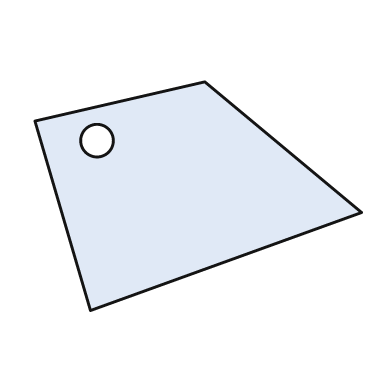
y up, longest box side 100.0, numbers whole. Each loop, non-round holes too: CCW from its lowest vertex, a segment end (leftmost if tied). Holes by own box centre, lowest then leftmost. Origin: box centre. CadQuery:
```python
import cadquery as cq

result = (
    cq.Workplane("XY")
    .moveTo(-33.0, -35.0)
    .lineTo(50.0, -5.0)
    .lineTo(2.0, 35.0)
    .lineTo(-50.0, 23.0)
    .close()
    .moveTo(-31.0, 17.0)
    .circle(5.0)
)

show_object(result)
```